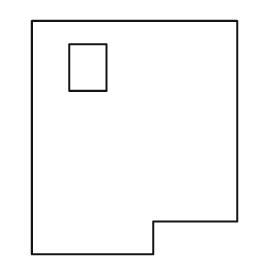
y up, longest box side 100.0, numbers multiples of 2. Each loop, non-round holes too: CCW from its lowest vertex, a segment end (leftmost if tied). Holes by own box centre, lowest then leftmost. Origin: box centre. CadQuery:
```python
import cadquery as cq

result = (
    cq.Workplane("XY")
    .moveTo(-44.0, -50.0)
    .lineTo(8.0, -50.0)
    .lineTo(8.0, -36.0)
    .lineTo(44.0, -36.0)
    .lineTo(44.0, 50.0)
    .lineTo(-44.0, 50.0)
    .close()
    .moveTo(-28.0, 20.0)
    .lineTo(-12.0, 20.0)
    .lineTo(-12.0, 40.0)
    .lineTo(-28.0, 40.0)
    .close()
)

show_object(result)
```